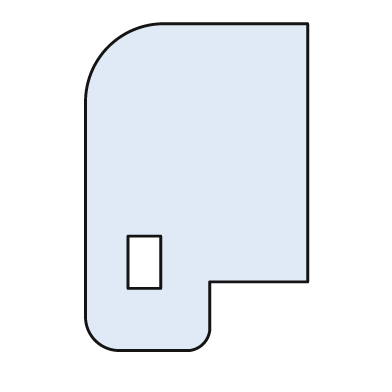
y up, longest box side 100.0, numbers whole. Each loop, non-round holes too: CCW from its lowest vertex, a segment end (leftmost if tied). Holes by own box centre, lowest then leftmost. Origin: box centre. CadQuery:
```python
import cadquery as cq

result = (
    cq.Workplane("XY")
    .moveTo(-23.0, -50.0)
    .lineTo(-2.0, -50.0)
    .threePointArc((2.0, -48.0), (4.0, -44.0))
    .lineTo(4.0, -29.0)
    .lineTo(34.0, -29.0)
    .lineTo(34.0, 50.0)
    .lineTo(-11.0, 50.0)
    .threePointArc((-27.0, 43.0), (-34.0, 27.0))
    .lineTo(-34.0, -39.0)
    .threePointArc((-31.0, -47.0), (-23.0, -50.0))
    .close()
    .moveTo(-21.0, -31.0)
    .lineTo(-11.0, -31.0)
    .lineTo(-11.0, -15.0)
    .lineTo(-21.0, -15.0)
    .close()
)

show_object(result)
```